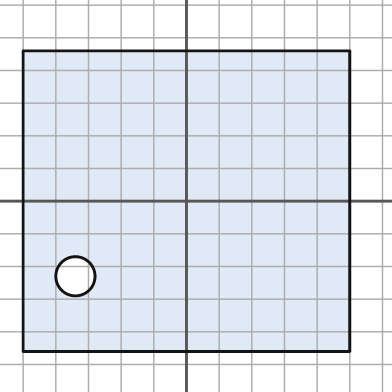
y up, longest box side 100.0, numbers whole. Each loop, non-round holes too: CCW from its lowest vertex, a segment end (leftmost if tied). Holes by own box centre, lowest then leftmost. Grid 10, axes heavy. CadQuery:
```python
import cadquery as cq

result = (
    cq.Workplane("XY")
    .moveTo(-50.0, -46.0)
    .lineTo(50.0, -46.0)
    .lineTo(50.0, 46.0)
    .lineTo(-50.0, 46.0)
    .close()
    .moveTo(-34.0, -23.0)
    .circle(6.0)
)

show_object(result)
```